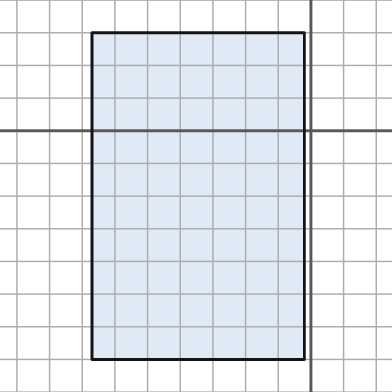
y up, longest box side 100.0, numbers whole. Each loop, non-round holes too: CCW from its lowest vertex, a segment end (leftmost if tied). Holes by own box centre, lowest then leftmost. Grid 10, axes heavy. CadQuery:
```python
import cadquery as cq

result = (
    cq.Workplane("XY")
    .moveTo(-67.0, -70.0)
    .lineTo(-2.0, -70.0)
    .lineTo(-2.0, 30.0)
    .lineTo(-67.0, 30.0)
    .close()
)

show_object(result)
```